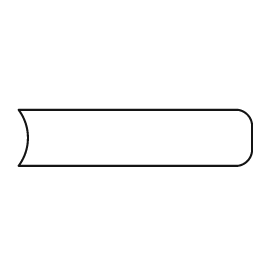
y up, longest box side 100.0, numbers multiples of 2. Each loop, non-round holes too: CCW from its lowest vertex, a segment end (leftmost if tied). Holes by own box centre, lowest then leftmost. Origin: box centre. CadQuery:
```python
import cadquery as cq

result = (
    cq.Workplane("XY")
    .moveTo(-50.0, -12.0)
    .lineTo(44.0, -12.0)
    .threePointArc((48.0, -10.0), (50.0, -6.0))
    .lineTo(50.0, 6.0)
    .threePointArc((48.0, 10.0), (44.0, 12.0))
    .lineTo(-50.0, 12.0)
    .threePointArc((-46.0, 0.0), (-50.0, -12.0))
    .close()
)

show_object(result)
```